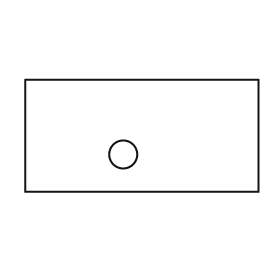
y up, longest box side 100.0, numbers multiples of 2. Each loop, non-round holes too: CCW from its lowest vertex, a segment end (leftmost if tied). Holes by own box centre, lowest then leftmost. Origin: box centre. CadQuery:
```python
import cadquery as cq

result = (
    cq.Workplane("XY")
    .moveTo(-50.0, -24.0)
    .lineTo(50.0, -24.0)
    .lineTo(50.0, 24.0)
    .lineTo(-50.0, 24.0)
    .close()
    .moveTo(-8.0, -8.0)
    .circle(6.0)
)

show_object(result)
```